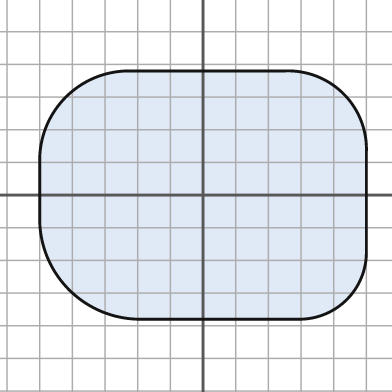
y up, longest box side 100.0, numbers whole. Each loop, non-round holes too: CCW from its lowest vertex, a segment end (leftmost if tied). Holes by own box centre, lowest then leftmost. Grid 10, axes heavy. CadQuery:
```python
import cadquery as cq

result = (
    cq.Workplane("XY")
    .moveTo(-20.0, -38.0)
    .lineTo(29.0, -38.0)
    .threePointArc((44.0, -32.0), (50.0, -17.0))
    .lineTo(50.0, 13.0)
    .threePointArc((43.0, 31.0), (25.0, 38.0))
    .lineTo(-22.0, 38.0)
    .threePointArc((-42.0, 30.0), (-50.0, 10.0))
    .lineTo(-50.0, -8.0)
    .threePointArc((-41.0, -29.0), (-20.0, -38.0))
    .close()
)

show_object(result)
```